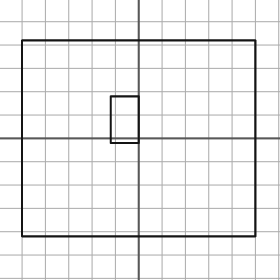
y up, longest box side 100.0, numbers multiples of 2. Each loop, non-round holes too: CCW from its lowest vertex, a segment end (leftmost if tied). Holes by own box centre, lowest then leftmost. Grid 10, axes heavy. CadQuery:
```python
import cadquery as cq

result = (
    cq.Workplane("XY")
    .moveTo(-50.0, -42.0)
    .lineTo(50.0, -42.0)
    .lineTo(50.0, 42.0)
    .lineTo(-50.0, 42.0)
    .close()
    .moveTo(-12.0, -2.0)
    .lineTo(0.0, -2.0)
    .lineTo(0.0, 18.0)
    .lineTo(-12.0, 18.0)
    .close()
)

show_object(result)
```